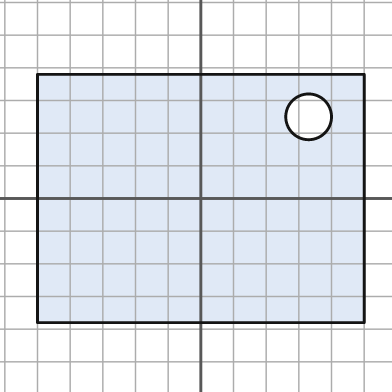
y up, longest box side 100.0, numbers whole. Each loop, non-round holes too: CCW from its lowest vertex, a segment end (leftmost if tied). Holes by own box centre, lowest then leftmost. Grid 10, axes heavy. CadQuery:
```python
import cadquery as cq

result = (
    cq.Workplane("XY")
    .moveTo(-50.0, -38.0)
    .lineTo(50.0, -38.0)
    .lineTo(50.0, 38.0)
    .lineTo(-50.0, 38.0)
    .close()
    .moveTo(33.0, 25.0)
    .circle(7.0)
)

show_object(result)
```